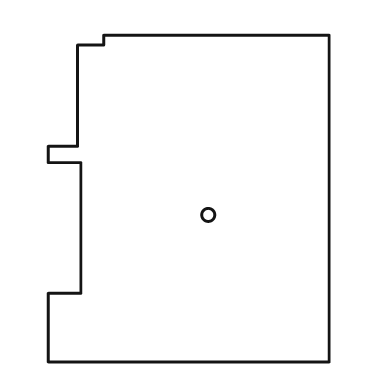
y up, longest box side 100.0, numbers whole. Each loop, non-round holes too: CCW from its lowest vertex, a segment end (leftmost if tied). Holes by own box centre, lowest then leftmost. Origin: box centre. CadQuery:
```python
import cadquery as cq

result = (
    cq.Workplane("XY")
    .moveTo(-43.0, -50.0)
    .lineTo(43.0, -50.0)
    .lineTo(43.0, 50.0)
    .lineTo(-26.0, 50.0)
    .lineTo(-26.0, 47.0)
    .lineTo(-34.0, 47.0)
    .lineTo(-34.0, 16.0)
    .lineTo(-43.0, 16.0)
    .lineTo(-43.0, 11.0)
    .lineTo(-33.0, 11.0)
    .lineTo(-33.0, -29.0)
    .lineTo(-43.0, -29.0)
    .close()
    .moveTo(6.0, -5.0)
    .circle(2.0)
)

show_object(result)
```